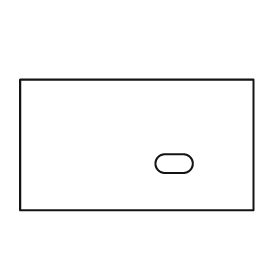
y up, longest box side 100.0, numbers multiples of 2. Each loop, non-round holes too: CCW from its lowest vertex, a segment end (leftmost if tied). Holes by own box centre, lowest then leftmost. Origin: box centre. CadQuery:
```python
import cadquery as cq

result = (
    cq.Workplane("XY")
    .moveTo(-50.0, -28.0)
    .lineTo(50.0, -28.0)
    .lineTo(50.0, 28.0)
    .lineTo(-50.0, 28.0)
    .close()
    .moveTo(12.0, -12.0)
    .lineTo(20.0, -12.0)
    .threePointArc((24.0, -8.0), (20.0, -4.0))
    .lineTo(12.0, -4.0)
    .threePointArc((8.0, -8.0), (12.0, -12.0))
    .close()
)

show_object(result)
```